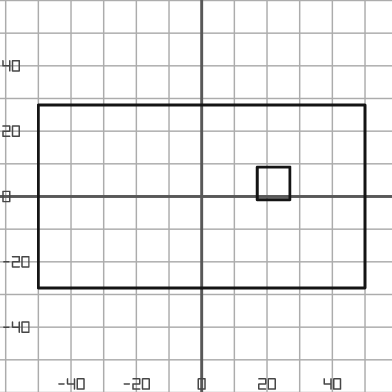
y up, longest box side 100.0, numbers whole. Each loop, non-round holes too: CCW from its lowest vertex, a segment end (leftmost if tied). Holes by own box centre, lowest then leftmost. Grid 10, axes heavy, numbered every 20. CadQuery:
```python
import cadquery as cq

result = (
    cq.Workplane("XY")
    .moveTo(-50.0, -28.0)
    .lineTo(50.0, -28.0)
    .lineTo(50.0, 28.0)
    .lineTo(-50.0, 28.0)
    .close()
    .moveTo(17.0, -1.0)
    .lineTo(27.0, -1.0)
    .lineTo(27.0, 9.0)
    .lineTo(17.0, 9.0)
    .close()
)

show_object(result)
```